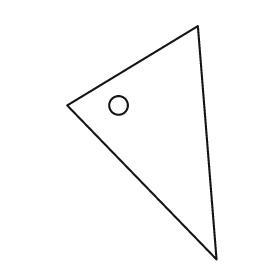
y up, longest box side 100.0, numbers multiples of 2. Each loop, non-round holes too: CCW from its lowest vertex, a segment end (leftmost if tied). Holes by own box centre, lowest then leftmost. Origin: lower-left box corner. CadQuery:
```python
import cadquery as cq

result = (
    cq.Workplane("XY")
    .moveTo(64.0, 0.0)
    .lineTo(56.0, 100.0)
    .lineTo(0.0, 66.0)
    .close()
    .moveTo(22.0, 66.0)
    .circle(4.0)
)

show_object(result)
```